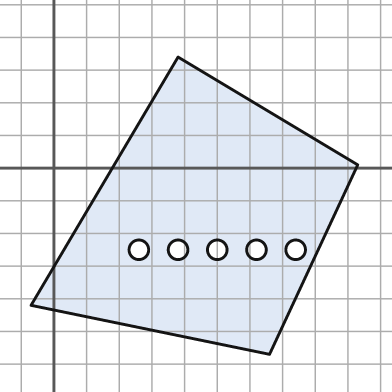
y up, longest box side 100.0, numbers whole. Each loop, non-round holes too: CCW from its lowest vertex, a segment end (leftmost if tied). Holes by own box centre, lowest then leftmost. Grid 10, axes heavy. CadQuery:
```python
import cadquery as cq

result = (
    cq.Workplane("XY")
    .moveTo(66.0, -57.0)
    .lineTo(93.0, 1.0)
    .lineTo(38.0, 34.0)
    .lineTo(-7.0, -42.0)
    .close()
    .moveTo(26.0, -25.0)
    .circle(3.0)
    .moveTo(38.0, -25.0)
    .circle(3.0)
    .moveTo(50.0, -25.0)
    .circle(3.0)
    .moveTo(62.0, -25.0)
    .circle(3.0)
    .moveTo(74.0, -25.0)
    .circle(3.0)
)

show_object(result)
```